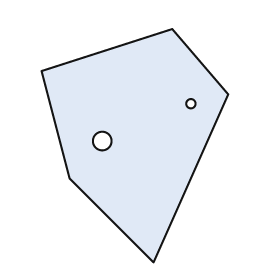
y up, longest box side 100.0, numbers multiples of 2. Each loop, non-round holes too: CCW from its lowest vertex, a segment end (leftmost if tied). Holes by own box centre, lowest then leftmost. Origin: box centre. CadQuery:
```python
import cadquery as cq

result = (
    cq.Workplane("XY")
    .moveTo(8.0, -50.0)
    .lineTo(40.0, 22.0)
    .lineTo(16.0, 50.0)
    .lineTo(-40.0, 32.0)
    .lineTo(-28.0, -14.0)
    .close()
    .moveTo(-14.0, 2.0)
    .circle(4.0)
    .moveTo(24.0, 18.0)
    .circle(2.0)
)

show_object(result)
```